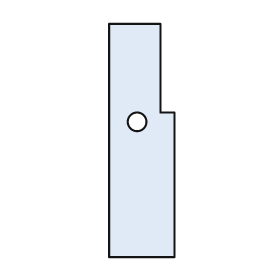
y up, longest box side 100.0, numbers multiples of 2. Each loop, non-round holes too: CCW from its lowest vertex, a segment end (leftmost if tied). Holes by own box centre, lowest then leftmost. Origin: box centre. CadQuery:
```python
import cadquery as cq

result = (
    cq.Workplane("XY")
    .moveTo(-14.0, -50.0)
    .lineTo(14.0, -50.0)
    .lineTo(14.0, 12.0)
    .lineTo(8.0, 12.0)
    .lineTo(8.0, 50.0)
    .lineTo(-14.0, 50.0)
    .close()
    .moveTo(-2.0, 8.0)
    .circle(4.0)
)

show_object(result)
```